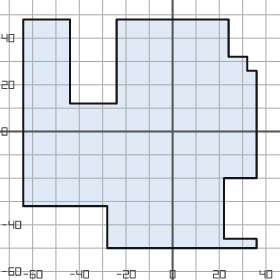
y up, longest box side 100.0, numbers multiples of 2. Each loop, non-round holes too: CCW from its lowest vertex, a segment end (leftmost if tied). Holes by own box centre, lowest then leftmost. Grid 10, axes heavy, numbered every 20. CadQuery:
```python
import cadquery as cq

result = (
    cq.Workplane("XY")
    .moveTo(-28.0, -50.0)
    .lineTo(36.0, -50.0)
    .lineTo(36.0, -46.0)
    .lineTo(22.0, -46.0)
    .lineTo(22.0, -20.0)
    .lineTo(36.0, -20.0)
    .lineTo(36.0, 26.0)
    .lineTo(32.0, 26.0)
    .lineTo(32.0, 32.0)
    .lineTo(24.0, 32.0)
    .lineTo(24.0, 48.0)
    .lineTo(-24.0, 48.0)
    .lineTo(-24.0, 12.0)
    .lineTo(-44.0, 12.0)
    .lineTo(-44.0, 48.0)
    .lineTo(-64.0, 48.0)
    .lineTo(-64.0, -32.0)
    .lineTo(-28.0, -32.0)
    .close()
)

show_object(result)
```